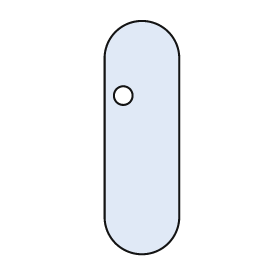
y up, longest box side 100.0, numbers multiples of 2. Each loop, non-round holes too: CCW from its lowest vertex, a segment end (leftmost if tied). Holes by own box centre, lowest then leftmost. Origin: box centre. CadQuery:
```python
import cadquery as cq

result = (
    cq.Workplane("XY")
    .moveTo(-16.0, -34.0)
    .threePointArc((0.0, -50.0), (16.0, -34.0))
    .lineTo(16.0, 34.0)
    .threePointArc((0.0, 50.0), (-16.0, 34.0))
    .close()
    .moveTo(-8.0, 18.0)
    .circle(4.0)
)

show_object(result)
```